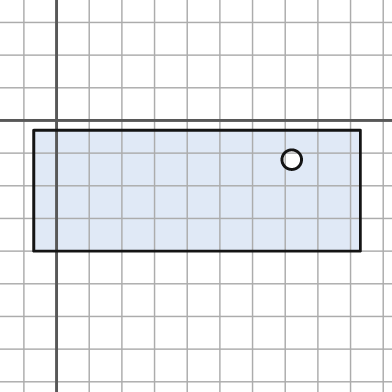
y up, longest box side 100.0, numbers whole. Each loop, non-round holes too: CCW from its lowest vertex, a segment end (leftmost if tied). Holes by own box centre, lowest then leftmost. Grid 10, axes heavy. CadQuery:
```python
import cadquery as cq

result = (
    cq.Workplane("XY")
    .moveTo(-7.0, -40.0)
    .lineTo(93.0, -40.0)
    .lineTo(93.0, -3.0)
    .lineTo(-7.0, -3.0)
    .close()
    .moveTo(72.0, -12.0)
    .circle(3.0)
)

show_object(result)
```